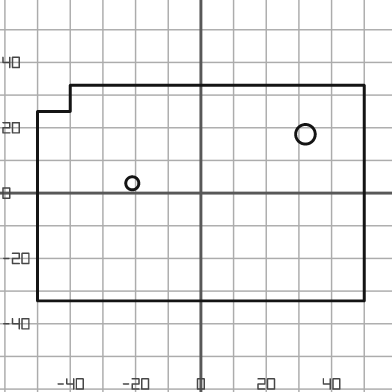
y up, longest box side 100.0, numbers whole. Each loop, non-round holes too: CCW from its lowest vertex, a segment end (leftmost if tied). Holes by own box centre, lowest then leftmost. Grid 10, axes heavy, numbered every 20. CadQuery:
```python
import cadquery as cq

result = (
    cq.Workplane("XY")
    .moveTo(-50.0, -33.0)
    .lineTo(50.0, -33.0)
    .lineTo(50.0, 33.0)
    .lineTo(-40.0, 33.0)
    .lineTo(-40.0, 25.0)
    .lineTo(-50.0, 25.0)
    .close()
    .moveTo(-21.0, 3.0)
    .circle(2.0)
    .moveTo(32.0, 18.0)
    .circle(3.0)
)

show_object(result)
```